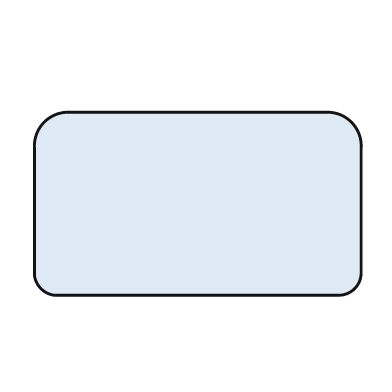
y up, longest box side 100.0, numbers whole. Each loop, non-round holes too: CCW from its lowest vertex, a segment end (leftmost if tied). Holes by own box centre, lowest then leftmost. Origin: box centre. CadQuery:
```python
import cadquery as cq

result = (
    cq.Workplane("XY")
    .moveTo(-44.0, -28.0)
    .lineTo(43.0, -28.0)
    .threePointArc((48.0, -26.0), (50.0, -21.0))
    .lineTo(50.0, 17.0)
    .threePointArc((47.0, 25.0), (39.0, 28.0))
    .lineTo(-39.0, 28.0)
    .threePointArc((-47.0, 25.0), (-50.0, 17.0))
    .lineTo(-50.0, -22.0)
    .threePointArc((-48.0, -26.0), (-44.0, -28.0))
    .close()
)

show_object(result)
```